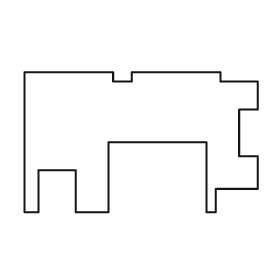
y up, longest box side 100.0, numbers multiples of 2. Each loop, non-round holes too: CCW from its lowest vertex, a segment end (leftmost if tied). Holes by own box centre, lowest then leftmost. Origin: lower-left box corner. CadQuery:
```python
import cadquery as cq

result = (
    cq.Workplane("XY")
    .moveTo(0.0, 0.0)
    .lineTo(6.0, 0.0)
    .lineTo(6.0, 18.0)
    .lineTo(22.0, 18.0)
    .lineTo(22.0, 0.0)
    .lineTo(36.0, 0.0)
    .lineTo(36.0, 30.0)
    .lineTo(78.0, 30.0)
    .lineTo(78.0, 0.0)
    .lineTo(82.0, 0.0)
    .lineTo(82.0, 10.0)
    .lineTo(100.0, 10.0)
    .lineTo(100.0, 24.0)
    .lineTo(92.0, 24.0)
    .lineTo(92.0, 44.0)
    .lineTo(100.0, 44.0)
    .lineTo(100.0, 56.0)
    .lineTo(84.0, 56.0)
    .lineTo(84.0, 60.0)
    .lineTo(46.0, 60.0)
    .lineTo(46.0, 56.0)
    .lineTo(38.0, 56.0)
    .lineTo(38.0, 60.0)
    .lineTo(0.0, 60.0)
    .close()
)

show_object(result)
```